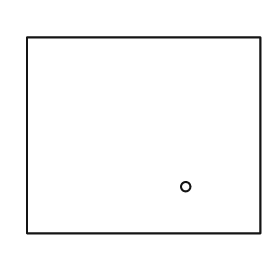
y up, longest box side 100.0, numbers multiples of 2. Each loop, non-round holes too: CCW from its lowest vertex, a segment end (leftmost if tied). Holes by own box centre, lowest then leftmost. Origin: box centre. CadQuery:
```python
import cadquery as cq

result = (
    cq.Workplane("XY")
    .moveTo(-50.0, -42.0)
    .lineTo(50.0, -42.0)
    .lineTo(50.0, 42.0)
    .lineTo(-50.0, 42.0)
    .close()
    .moveTo(18.0, -22.0)
    .circle(2.0)
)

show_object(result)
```